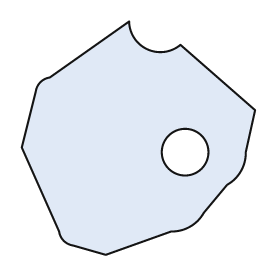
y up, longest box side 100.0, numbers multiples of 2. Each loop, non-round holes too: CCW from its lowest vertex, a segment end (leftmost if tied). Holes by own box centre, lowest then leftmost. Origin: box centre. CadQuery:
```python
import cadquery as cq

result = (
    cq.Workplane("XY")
    .moveTo(-14.0, -50.0)
    .lineTo(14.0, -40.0)
    .threePointArc((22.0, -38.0), (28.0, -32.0))
    .lineTo(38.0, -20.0)
    .threePointArc((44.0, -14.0), (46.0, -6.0))
    .lineTo(50.0, 12.0)
    .lineTo(18.0, 40.0)
    .threePointArc((4.0, 38.0), (-4.0, 50.0))
    .lineTo(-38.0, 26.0)
    .threePointArc((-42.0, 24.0), (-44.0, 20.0))
    .lineTo(-50.0, -4.0)
    .lineTo(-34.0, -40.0)
    .threePointArc((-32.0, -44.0), (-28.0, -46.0))
    .close()
    .moveTo(20.0, -6.0)
    .circle(10.0)
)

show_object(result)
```